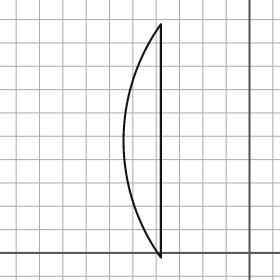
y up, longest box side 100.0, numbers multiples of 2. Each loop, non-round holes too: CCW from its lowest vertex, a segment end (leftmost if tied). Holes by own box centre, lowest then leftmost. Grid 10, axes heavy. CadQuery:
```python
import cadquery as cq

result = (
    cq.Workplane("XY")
    .moveTo(-38.0, -2.0)
    .lineTo(-38.0, 98.0)
    .threePointArc((-54.0, 48.0), (-38.0, -2.0))
    .close()
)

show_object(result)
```